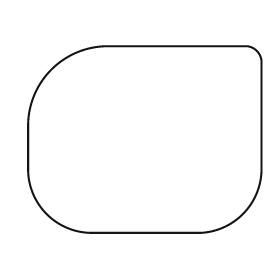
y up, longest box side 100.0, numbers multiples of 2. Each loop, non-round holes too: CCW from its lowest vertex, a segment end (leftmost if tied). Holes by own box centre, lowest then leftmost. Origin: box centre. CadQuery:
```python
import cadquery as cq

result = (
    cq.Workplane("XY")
    .moveTo(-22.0, -40.0)
    .lineTo(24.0, -40.0)
    .threePointArc((42.0, -32.0), (50.0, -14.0))
    .lineTo(50.0, 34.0)
    .threePointArc((48.0, 38.0), (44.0, 40.0))
    .lineTo(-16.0, 40.0)
    .threePointArc((-40.0, 30.0), (-50.0, 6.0))
    .lineTo(-50.0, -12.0)
    .threePointArc((-42.0, -32.0), (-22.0, -40.0))
    .close()
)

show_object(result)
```